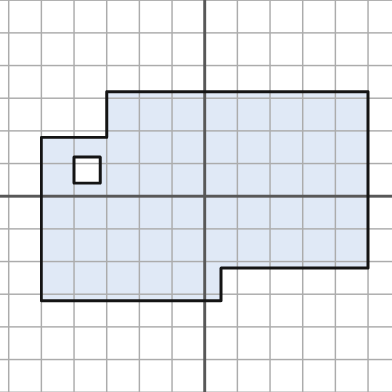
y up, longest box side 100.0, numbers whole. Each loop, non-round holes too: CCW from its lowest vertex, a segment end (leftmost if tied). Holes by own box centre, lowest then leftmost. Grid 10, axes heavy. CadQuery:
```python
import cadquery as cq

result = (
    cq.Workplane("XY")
    .moveTo(-50.0, -32.0)
    .lineTo(5.0, -32.0)
    .lineTo(5.0, -22.0)
    .lineTo(50.0, -22.0)
    .lineTo(50.0, 32.0)
    .lineTo(-30.0, 32.0)
    .lineTo(-30.0, 18.0)
    .lineTo(-50.0, 18.0)
    .close()
    .moveTo(-40.0, 4.0)
    .lineTo(-32.0, 4.0)
    .lineTo(-32.0, 12.0)
    .lineTo(-40.0, 12.0)
    .close()
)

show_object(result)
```